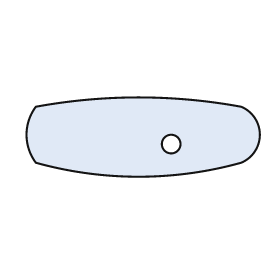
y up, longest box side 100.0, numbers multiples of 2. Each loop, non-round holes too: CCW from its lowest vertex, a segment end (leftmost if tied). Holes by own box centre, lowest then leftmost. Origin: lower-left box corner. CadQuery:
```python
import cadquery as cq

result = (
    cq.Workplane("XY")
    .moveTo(4.0, 6.0)
    .threePointArc((48.0, 0.0), (92.0, 6.0))
    .threePointArc((100.0, 18.0), (92.0, 30.0))
    .threePointArc((48.0, 34.0), (4.0, 30.0))
    .threePointArc((0.0, 18.0), (4.0, 6.0))
    .close()
    .moveTo(62.0, 14.0)
    .circle(4.0)
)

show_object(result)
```